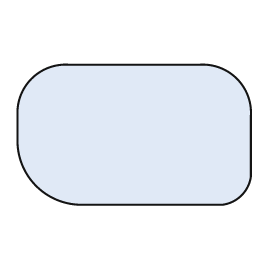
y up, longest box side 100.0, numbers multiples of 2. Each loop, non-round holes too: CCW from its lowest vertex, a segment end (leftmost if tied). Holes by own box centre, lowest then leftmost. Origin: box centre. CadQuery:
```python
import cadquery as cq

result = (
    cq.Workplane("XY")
    .moveTo(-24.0, -30.0)
    .lineTo(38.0, -30.0)
    .threePointArc((46.0, -26.0), (50.0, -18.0))
    .lineTo(50.0, 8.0)
    .threePointArc((44.0, 24.0), (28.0, 30.0))
    .lineTo(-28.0, 30.0)
    .threePointArc((-44.0, 24.0), (-50.0, 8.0))
    .lineTo(-50.0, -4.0)
    .threePointArc((-42.0, -22.0), (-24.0, -30.0))
    .close()
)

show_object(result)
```